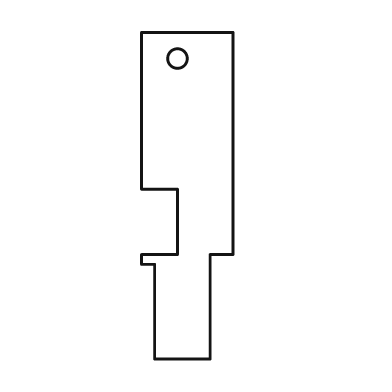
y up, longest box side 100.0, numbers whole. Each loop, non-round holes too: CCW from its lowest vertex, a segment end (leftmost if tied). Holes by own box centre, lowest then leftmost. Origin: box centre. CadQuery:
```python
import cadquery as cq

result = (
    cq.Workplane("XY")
    .moveTo(-10.0, -50.0)
    .lineTo(7.0, -50.0)
    .lineTo(7.0, -18.0)
    .lineTo(14.0, -18.0)
    .lineTo(14.0, 50.0)
    .lineTo(-14.0, 50.0)
    .lineTo(-14.0, 2.0)
    .lineTo(-3.0, 2.0)
    .lineTo(-3.0, -18.0)
    .lineTo(-14.0, -18.0)
    .lineTo(-14.0, -21.0)
    .lineTo(-10.0, -21.0)
    .close()
    .moveTo(-3.0, 42.0)
    .circle(3.0)
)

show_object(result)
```